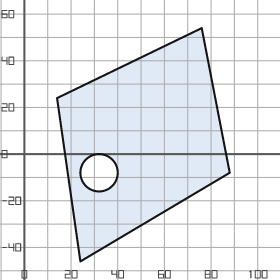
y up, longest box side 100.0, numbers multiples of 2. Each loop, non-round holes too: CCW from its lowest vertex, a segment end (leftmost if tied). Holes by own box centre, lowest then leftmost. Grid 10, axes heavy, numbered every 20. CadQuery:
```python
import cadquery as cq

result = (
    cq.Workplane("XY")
    .moveTo(24.0, -46.0)
    .lineTo(88.0, -8.0)
    .lineTo(76.0, 54.0)
    .lineTo(14.0, 24.0)
    .close()
    .moveTo(32.0, -8.0)
    .circle(8.0)
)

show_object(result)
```